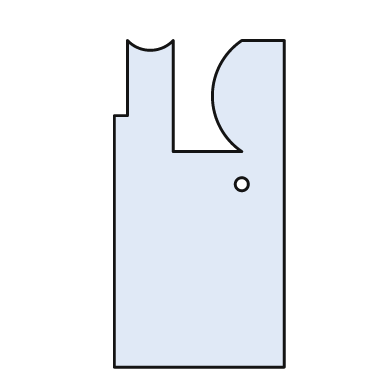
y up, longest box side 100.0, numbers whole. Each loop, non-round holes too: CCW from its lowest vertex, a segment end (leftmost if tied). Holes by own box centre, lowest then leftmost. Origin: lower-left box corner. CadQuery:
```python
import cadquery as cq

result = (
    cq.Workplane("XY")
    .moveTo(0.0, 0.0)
    .lineTo(52.0, 0.0)
    .lineTo(52.0, 100.0)
    .lineTo(39.0, 100.0)
    .threePointArc((30.0, 83.0), (39.0, 66.0))
    .lineTo(18.0, 66.0)
    .lineTo(18.0, 100.0)
    .threePointArc((11.0, 97.0), (4.0, 100.0))
    .lineTo(4.0, 77.0)
    .lineTo(0.0, 77.0)
    .close()
    .moveTo(39.0, 56.0)
    .circle(2.0)
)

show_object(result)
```